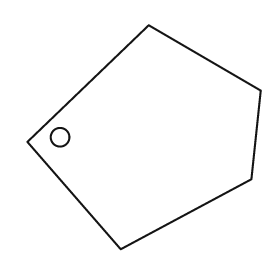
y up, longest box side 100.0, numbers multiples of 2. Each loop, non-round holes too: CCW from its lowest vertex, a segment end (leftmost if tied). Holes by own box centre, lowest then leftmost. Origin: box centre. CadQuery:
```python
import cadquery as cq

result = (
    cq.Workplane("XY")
    .moveTo(-10.0, -48.0)
    .lineTo(46.0, -18.0)
    .lineTo(50.0, 20.0)
    .lineTo(2.0, 48.0)
    .lineTo(-50.0, -2.0)
    .close()
    .moveTo(-36.0, 0.0)
    .circle(4.0)
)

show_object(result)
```